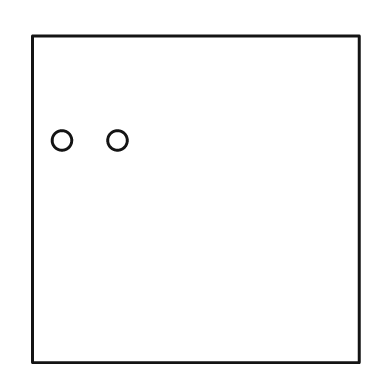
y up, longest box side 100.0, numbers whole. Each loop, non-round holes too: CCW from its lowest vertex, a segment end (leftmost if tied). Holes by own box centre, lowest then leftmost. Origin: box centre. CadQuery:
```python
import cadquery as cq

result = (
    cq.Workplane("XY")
    .moveTo(-50.0, -50.0)
    .lineTo(50.0, -50.0)
    .lineTo(50.0, 50.0)
    .lineTo(-50.0, 50.0)
    .close()
    .moveTo(-41.0, 18.0)
    .circle(3.0)
    .moveTo(-24.0, 18.0)
    .circle(3.0)
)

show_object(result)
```